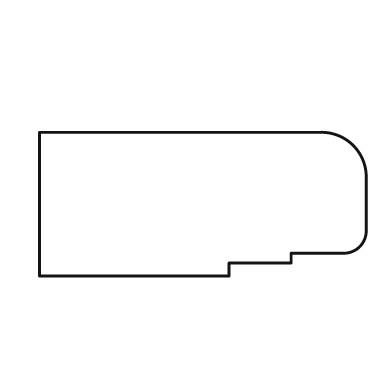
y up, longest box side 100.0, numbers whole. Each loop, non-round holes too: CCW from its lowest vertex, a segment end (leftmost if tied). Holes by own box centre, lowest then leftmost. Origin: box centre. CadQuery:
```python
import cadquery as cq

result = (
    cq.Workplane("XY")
    .moveTo(-50.0, -22.0)
    .lineTo(8.0, -22.0)
    .lineTo(8.0, -18.0)
    .lineTo(27.0, -18.0)
    .lineTo(27.0, -15.0)
    .lineTo(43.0, -15.0)
    .threePointArc((48.0, -13.0), (50.0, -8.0))
    .lineTo(50.0, 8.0)
    .threePointArc((46.0, 18.0), (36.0, 22.0))
    .lineTo(-50.0, 22.0)
    .close()
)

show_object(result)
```